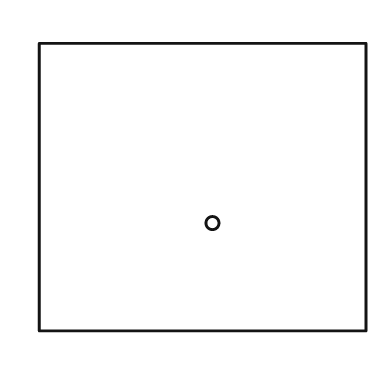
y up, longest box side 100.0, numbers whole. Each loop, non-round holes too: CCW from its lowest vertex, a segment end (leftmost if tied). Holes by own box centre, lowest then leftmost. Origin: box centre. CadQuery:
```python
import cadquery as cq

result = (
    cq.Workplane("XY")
    .moveTo(-50.0, -44.0)
    .lineTo(50.0, -44.0)
    .lineTo(50.0, 44.0)
    .lineTo(-50.0, 44.0)
    .close()
    .moveTo(3.0, -11.0)
    .circle(2.0)
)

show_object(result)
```